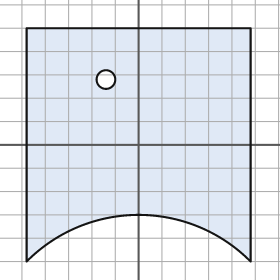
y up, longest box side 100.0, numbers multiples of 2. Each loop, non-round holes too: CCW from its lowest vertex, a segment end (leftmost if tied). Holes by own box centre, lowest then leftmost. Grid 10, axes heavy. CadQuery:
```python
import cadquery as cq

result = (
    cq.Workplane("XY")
    .moveTo(-48.0, -50.0)
    .threePointArc((0.0, -30.0), (48.0, -50.0))
    .lineTo(48.0, 50.0)
    .lineTo(-48.0, 50.0)
    .close()
    .moveTo(-14.0, 28.0)
    .circle(4.0)
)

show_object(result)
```